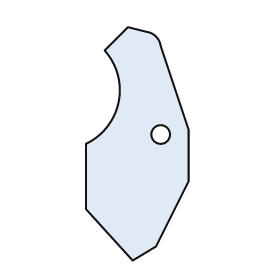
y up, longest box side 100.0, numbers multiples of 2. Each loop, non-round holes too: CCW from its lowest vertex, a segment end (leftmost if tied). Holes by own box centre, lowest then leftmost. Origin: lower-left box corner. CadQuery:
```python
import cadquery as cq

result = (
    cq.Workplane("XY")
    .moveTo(20.0, 0.0)
    .lineTo(30.0, 6.0)
    .lineTo(44.0, 34.0)
    .lineTo(44.0, 56.0)
    .lineTo(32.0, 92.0)
    .threePointArc((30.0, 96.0), (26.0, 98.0))
    .lineTo(18.0, 100.0)
    .lineTo(8.0, 90.0)
    .threePointArc((14.0, 68.0), (0.0, 50.0))
    .lineTo(0.0, 22.0)
    .close()
    .moveTo(32.0, 54.0)
    .circle(4.0)
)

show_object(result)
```